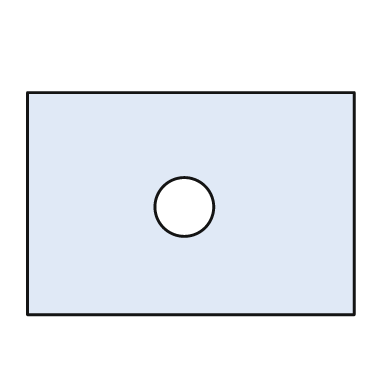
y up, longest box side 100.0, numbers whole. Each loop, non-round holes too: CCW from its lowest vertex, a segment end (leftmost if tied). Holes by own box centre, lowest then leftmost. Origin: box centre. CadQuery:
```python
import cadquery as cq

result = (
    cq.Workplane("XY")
    .moveTo(-50.0, -34.0)
    .lineTo(50.0, -34.0)
    .lineTo(50.0, 34.0)
    .lineTo(-50.0, 34.0)
    .close()
    .moveTo(-2.0, -1.0)
    .circle(9.0)
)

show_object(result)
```